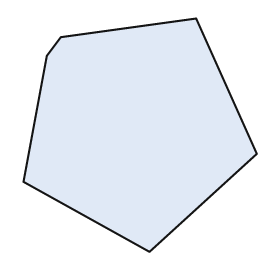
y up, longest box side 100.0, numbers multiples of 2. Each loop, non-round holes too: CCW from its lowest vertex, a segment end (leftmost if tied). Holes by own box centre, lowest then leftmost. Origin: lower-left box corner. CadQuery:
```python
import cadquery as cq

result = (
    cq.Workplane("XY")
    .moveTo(54.0, 0.0)
    .lineTo(100.0, 42.0)
    .lineTo(74.0, 100.0)
    .lineTo(16.0, 92.0)
    .lineTo(10.0, 84.0)
    .lineTo(0.0, 30.0)
    .close()
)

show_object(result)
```